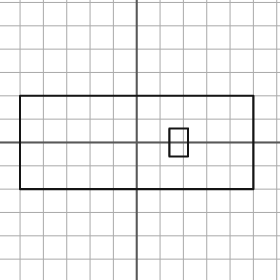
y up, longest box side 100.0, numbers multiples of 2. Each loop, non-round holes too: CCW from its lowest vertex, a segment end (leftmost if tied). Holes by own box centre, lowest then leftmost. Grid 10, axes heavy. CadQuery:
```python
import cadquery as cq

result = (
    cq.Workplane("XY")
    .moveTo(-50.0, -20.0)
    .lineTo(50.0, -20.0)
    .lineTo(50.0, 20.0)
    .lineTo(-50.0, 20.0)
    .close()
    .moveTo(14.0, -6.0)
    .lineTo(22.0, -6.0)
    .lineTo(22.0, 6.0)
    .lineTo(14.0, 6.0)
    .close()
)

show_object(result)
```